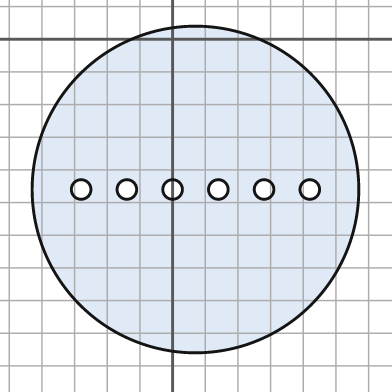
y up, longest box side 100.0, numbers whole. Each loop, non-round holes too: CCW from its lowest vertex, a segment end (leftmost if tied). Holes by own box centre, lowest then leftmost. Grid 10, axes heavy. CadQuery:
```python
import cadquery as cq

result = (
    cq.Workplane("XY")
    .moveTo(7.0, -46.0)
    .circle(50.0)
    .moveTo(-28.0, -46.0)
    .circle(3.0)
    .moveTo(-14.0, -46.0)
    .circle(3.0)
    .moveTo(0.0, -46.0)
    .circle(3.0)
    .moveTo(14.0, -46.0)
    .circle(3.0)
    .moveTo(28.0, -46.0)
    .circle(3.0)
    .moveTo(42.0, -46.0)
    .circle(3.0)
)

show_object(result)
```